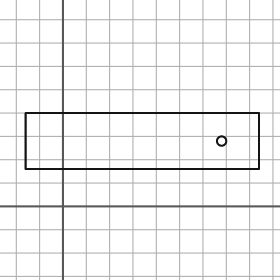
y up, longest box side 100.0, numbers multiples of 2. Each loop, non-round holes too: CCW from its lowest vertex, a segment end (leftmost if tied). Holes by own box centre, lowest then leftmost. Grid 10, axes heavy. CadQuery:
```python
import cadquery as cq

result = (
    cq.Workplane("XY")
    .moveTo(-16.0, 16.0)
    .lineTo(84.0, 16.0)
    .lineTo(84.0, 40.0)
    .lineTo(-16.0, 40.0)
    .close()
    .moveTo(68.0, 28.0)
    .circle(2.0)
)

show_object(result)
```